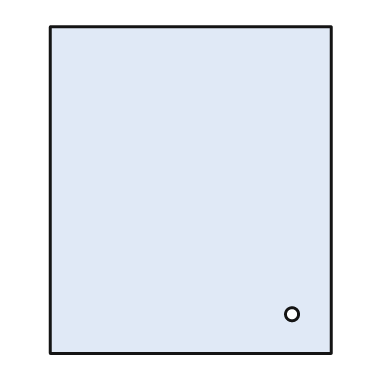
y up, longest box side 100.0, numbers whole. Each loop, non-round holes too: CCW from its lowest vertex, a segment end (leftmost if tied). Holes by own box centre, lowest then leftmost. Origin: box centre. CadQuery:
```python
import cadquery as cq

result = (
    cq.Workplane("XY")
    .moveTo(-43.0, -50.0)
    .lineTo(43.0, -50.0)
    .lineTo(43.0, 50.0)
    .lineTo(-43.0, 50.0)
    .close()
    .moveTo(31.0, -38.0)
    .circle(2.0)
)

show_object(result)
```